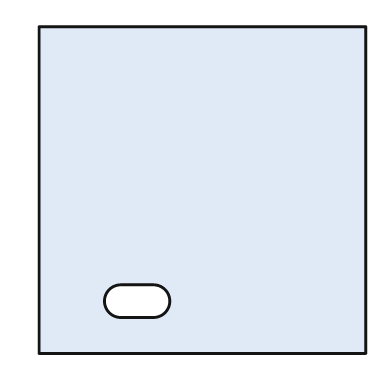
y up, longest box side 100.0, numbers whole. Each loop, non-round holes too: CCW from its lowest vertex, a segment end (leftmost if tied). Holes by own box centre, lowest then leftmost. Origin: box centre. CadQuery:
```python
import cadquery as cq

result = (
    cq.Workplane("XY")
    .moveTo(-50.0, -50.0)
    .lineTo(50.0, -50.0)
    .lineTo(50.0, 50.0)
    .lineTo(-50.0, 50.0)
    .close()
    .moveTo(-25.0, -39.0)
    .lineTo(-15.0, -39.0)
    .threePointArc((-10.0, -34.0), (-15.0, -29.0))
    .lineTo(-25.0, -29.0)
    .threePointArc((-30.0, -34.0), (-25.0, -39.0))
    .close()
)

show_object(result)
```